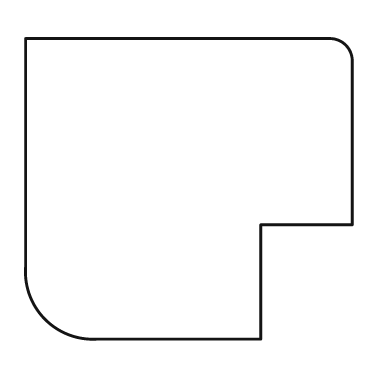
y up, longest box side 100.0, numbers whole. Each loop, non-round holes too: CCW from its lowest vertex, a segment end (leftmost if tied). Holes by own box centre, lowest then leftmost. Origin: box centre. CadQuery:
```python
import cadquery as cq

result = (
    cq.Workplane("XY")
    .moveTo(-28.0, -46.0)
    .lineTo(22.0, -46.0)
    .lineTo(22.0, -11.0)
    .lineTo(50.0, -11.0)
    .lineTo(50.0, 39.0)
    .threePointArc((48.0, 44.0), (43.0, 46.0))
    .lineTo(-50.0, 46.0)
    .lineTo(-50.0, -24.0)
    .threePointArc((-44.0, -40.0), (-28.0, -46.0))
    .close()
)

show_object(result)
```